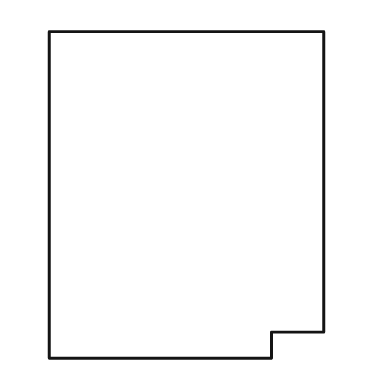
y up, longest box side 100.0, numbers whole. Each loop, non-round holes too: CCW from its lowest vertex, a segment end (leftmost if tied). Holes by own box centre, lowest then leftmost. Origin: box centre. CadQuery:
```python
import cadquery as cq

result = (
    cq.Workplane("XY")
    .moveTo(-42.0, -50.0)
    .lineTo(26.0, -50.0)
    .lineTo(26.0, -42.0)
    .lineTo(42.0, -42.0)
    .lineTo(42.0, 50.0)
    .lineTo(-42.0, 50.0)
    .close()
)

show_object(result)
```